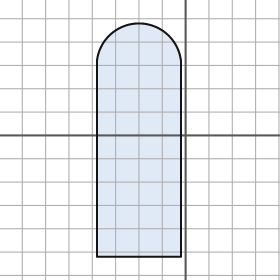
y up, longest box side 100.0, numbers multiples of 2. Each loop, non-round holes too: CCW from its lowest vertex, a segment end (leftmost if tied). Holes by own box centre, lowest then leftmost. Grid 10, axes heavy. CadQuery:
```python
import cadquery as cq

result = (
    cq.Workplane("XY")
    .moveTo(-38.0, -52.0)
    .lineTo(-2.0, -52.0)
    .lineTo(-2.0, 32.0)
    .threePointArc((-20.0, 48.0), (-38.0, 32.0))
    .close()
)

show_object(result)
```